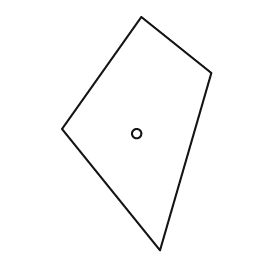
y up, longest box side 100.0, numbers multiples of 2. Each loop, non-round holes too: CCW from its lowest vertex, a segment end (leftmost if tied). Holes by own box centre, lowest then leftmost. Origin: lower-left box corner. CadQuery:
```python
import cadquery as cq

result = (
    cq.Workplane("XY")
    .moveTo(42.0, 0.0)
    .lineTo(64.0, 76.0)
    .lineTo(34.0, 100.0)
    .lineTo(0.0, 52.0)
    .close()
    .moveTo(32.0, 50.0)
    .circle(2.0)
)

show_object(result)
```